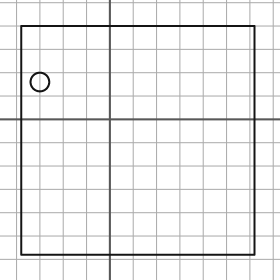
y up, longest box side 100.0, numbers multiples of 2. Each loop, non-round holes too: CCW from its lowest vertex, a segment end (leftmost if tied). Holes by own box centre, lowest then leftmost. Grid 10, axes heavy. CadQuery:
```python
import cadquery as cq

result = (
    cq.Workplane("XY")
    .moveTo(-38.0, -58.0)
    .lineTo(62.0, -58.0)
    .lineTo(62.0, 40.0)
    .lineTo(-38.0, 40.0)
    .close()
    .moveTo(-30.0, 16.0)
    .circle(4.0)
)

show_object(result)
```